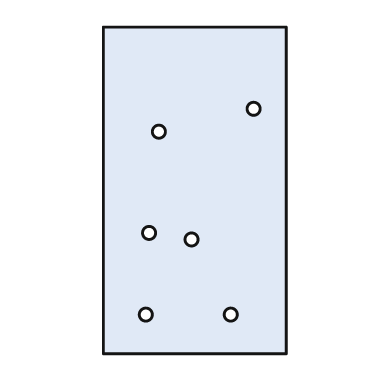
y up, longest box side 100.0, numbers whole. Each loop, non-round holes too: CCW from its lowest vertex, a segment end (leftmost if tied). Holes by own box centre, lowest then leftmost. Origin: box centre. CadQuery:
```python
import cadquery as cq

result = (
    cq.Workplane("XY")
    .moveTo(-28.0, -50.0)
    .lineTo(28.0, -50.0)
    .lineTo(28.0, 50.0)
    .lineTo(-28.0, 50.0)
    .close()
    .moveTo(-15.0, -38.0)
    .circle(2.0)
    .moveTo(11.0, -38.0)
    .circle(2.0)
    .moveTo(-1.0, -15.0)
    .circle(2.0)
    .moveTo(-14.0, -13.0)
    .circle(2.0)
    .moveTo(-11.0, 18.0)
    .circle(2.0)
    .moveTo(18.0, 25.0)
    .circle(2.0)
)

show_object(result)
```